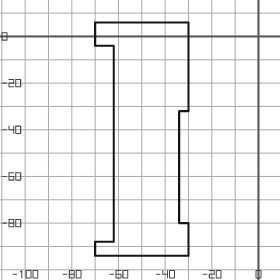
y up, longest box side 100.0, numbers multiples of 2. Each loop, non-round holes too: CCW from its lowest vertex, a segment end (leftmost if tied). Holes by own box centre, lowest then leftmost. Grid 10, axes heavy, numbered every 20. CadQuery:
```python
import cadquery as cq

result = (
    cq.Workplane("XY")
    .moveTo(-70.0, -94.0)
    .lineTo(-30.0, -94.0)
    .lineTo(-30.0, -80.0)
    .lineTo(-34.0, -80.0)
    .lineTo(-34.0, -32.0)
    .lineTo(-30.0, -32.0)
    .lineTo(-30.0, 6.0)
    .lineTo(-70.0, 6.0)
    .lineTo(-70.0, -4.0)
    .lineTo(-62.0, -4.0)
    .lineTo(-62.0, -88.0)
    .lineTo(-70.0, -88.0)
    .close()
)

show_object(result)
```